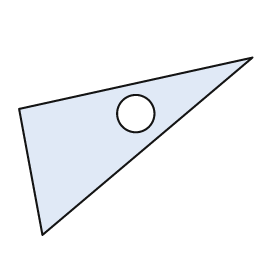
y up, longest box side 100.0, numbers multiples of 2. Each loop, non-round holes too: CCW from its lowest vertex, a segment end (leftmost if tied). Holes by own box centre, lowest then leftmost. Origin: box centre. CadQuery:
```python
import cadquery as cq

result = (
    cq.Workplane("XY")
    .moveTo(-40.0, -38.0)
    .lineTo(50.0, 38.0)
    .lineTo(-50.0, 16.0)
    .close()
    .moveTo(0.0, 14.0)
    .circle(8.0)
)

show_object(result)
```